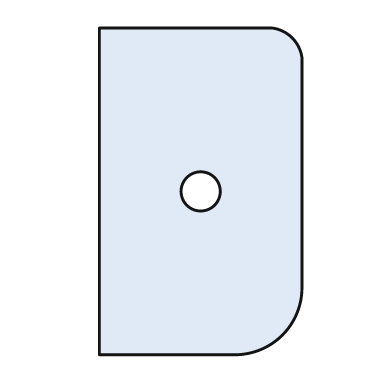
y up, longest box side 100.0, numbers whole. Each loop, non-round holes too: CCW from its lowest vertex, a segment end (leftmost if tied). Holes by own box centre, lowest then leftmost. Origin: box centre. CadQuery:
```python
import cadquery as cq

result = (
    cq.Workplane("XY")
    .moveTo(-31.0, -50.0)
    .lineTo(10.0, -50.0)
    .threePointArc((25.0, -44.0), (31.0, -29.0))
    .lineTo(31.0, 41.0)
    .threePointArc((28.0, 47.0), (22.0, 50.0))
    .lineTo(-31.0, 50.0)
    .close()
    .moveTo(0.0, 0.0)
    .circle(6.0)
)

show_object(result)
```